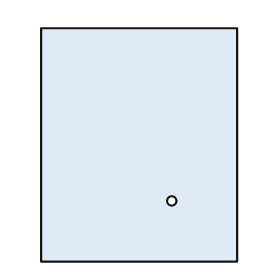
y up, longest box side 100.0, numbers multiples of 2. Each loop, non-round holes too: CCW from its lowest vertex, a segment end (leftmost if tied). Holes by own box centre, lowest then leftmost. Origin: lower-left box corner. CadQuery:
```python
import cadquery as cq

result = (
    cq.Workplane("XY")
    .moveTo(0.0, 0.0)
    .lineTo(84.0, 0.0)
    .lineTo(84.0, 100.0)
    .lineTo(0.0, 100.0)
    .close()
    .moveTo(56.0, 26.0)
    .circle(2.0)
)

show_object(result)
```